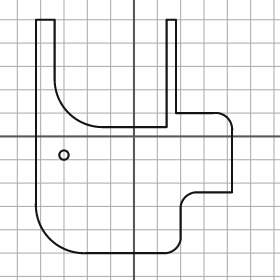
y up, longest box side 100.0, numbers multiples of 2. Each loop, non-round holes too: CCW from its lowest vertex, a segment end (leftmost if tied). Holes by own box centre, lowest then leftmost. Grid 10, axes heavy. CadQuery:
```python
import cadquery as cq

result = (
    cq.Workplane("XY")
    .moveTo(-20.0, -50.0)
    .lineTo(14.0, -50.0)
    .threePointArc((18.0, -48.0), (20.0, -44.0))
    .lineTo(20.0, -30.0)
    .threePointArc((22.0, -26.0), (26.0, -24.0))
    .lineTo(42.0, -24.0)
    .lineTo(42.0, 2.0)
    .threePointArc((40.0, 8.0), (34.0, 10.0))
    .lineTo(18.0, 10.0)
    .lineTo(18.0, 50.0)
    .lineTo(14.0, 50.0)
    .lineTo(14.0, 4.0)
    .lineTo(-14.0, 4.0)
    .threePointArc((-28.0, 10.0), (-34.0, 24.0))
    .lineTo(-34.0, 50.0)
    .lineTo(-42.0, 50.0)
    .lineTo(-42.0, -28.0)
    .threePointArc((-36.0, -44.0), (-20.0, -50.0))
    .close()
    .moveTo(-30.0, -8.0)
    .circle(2.0)
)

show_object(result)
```